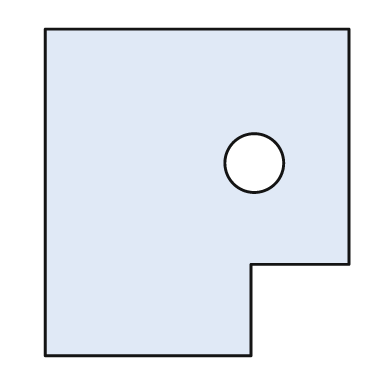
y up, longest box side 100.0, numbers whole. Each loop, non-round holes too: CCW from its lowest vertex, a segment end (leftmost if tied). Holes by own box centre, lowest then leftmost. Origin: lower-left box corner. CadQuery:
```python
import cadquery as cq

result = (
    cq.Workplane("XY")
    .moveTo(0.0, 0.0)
    .lineTo(63.0, 0.0)
    .lineTo(63.0, 28.0)
    .lineTo(93.0, 28.0)
    .lineTo(93.0, 100.0)
    .lineTo(0.0, 100.0)
    .close()
    .moveTo(64.0, 59.0)
    .circle(9.0)
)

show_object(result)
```